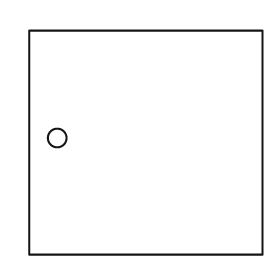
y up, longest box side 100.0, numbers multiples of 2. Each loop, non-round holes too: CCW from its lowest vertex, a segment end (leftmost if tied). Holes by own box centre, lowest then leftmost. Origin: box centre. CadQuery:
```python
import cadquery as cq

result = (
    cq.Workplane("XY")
    .moveTo(-50.0, -48.0)
    .lineTo(50.0, -48.0)
    .lineTo(50.0, 48.0)
    .lineTo(-50.0, 48.0)
    .close()
    .moveTo(-38.0, 2.0)
    .circle(4.0)
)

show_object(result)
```